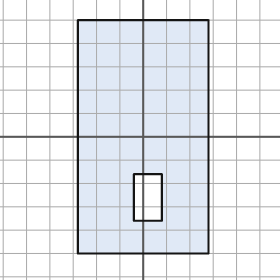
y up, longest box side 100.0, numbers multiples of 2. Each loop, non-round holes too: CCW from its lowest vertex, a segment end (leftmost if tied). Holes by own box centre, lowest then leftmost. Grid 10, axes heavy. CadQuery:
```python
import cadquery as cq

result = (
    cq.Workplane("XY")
    .moveTo(-28.0, -50.0)
    .lineTo(28.0, -50.0)
    .lineTo(28.0, 50.0)
    .lineTo(-28.0, 50.0)
    .close()
    .moveTo(-4.0, -36.0)
    .lineTo(8.0, -36.0)
    .lineTo(8.0, -16.0)
    .lineTo(-4.0, -16.0)
    .close()
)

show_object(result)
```